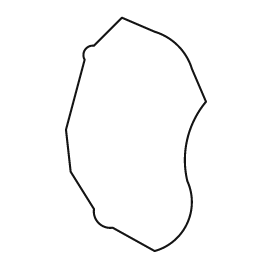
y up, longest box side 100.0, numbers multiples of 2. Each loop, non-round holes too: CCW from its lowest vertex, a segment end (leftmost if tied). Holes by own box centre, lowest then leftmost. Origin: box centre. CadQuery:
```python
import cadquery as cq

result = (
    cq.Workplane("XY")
    .moveTo(8.0, -50.0)
    .threePointArc((22.0, -38.0), (22.0, -20.0))
    .threePointArc((22.0, -2.0), (30.0, 14.0))
    .lineTo(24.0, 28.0)
    .threePointArc((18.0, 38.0), (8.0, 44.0))
    .lineTo(-6.0, 50.0)
    .lineTo(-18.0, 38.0)
    .threePointArc((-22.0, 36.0), (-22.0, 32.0))
    .lineTo(-30.0, 2.0)
    .lineTo(-28.0, -16.0)
    .lineTo(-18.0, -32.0)
    .threePointArc((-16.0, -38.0), (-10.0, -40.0))
    .close()
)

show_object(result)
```